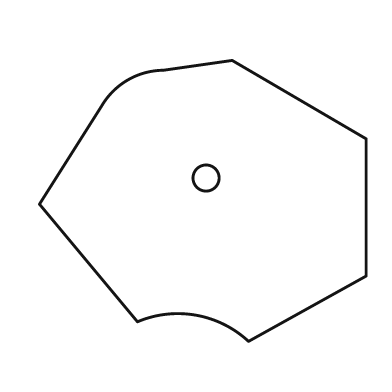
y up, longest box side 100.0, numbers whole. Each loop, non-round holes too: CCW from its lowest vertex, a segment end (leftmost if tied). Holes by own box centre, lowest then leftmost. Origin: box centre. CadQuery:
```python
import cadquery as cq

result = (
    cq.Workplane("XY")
    .moveTo(14.0, -43.0)
    .lineTo(50.0, -23.0)
    .lineTo(50.0, 19.0)
    .lineTo(9.0, 43.0)
    .lineTo(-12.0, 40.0)
    .threePointArc((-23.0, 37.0), (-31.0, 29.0))
    .lineTo(-50.0, -1.0)
    .lineTo(-20.0, -37.0)
    .threePointArc((-2.0, -35.0), (14.0, -43.0))
    .close()
    .moveTo(1.0, 7.0)
    .circle(4.0)
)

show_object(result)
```